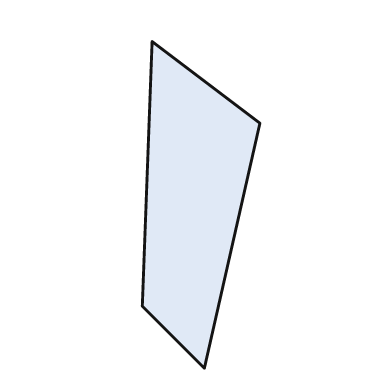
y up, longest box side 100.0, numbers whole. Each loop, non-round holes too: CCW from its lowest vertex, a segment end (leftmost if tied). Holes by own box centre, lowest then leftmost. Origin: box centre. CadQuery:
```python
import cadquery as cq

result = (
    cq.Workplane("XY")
    .moveTo(1.0, -50.0)
    .lineTo(18.0, 25.0)
    .lineTo(-15.0, 50.0)
    .lineTo(-18.0, -31.0)
    .close()
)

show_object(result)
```